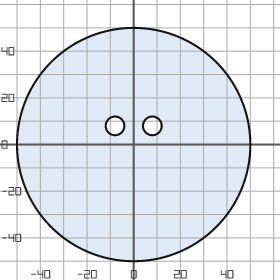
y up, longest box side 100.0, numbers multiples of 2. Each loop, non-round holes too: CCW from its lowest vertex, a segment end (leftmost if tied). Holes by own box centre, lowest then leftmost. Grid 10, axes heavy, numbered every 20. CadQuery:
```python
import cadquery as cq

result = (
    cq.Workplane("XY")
    .moveTo(0.0, 0.0)
    .circle(50.0)
    .moveTo(-8.0, 8.0)
    .circle(4.0)
    .moveTo(8.0, 8.0)
    .circle(4.0)
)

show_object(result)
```